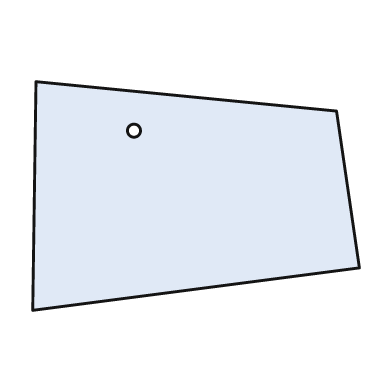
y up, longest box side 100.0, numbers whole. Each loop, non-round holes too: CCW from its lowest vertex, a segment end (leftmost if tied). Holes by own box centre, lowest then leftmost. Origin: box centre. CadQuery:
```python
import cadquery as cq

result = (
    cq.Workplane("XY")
    .moveTo(-50.0, -35.0)
    .lineTo(50.0, -22.0)
    .lineTo(43.0, 26.0)
    .lineTo(-49.0, 35.0)
    .close()
    .moveTo(-19.0, 20.0)
    .circle(2.0)
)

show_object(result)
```